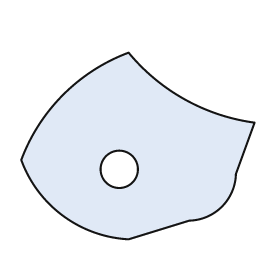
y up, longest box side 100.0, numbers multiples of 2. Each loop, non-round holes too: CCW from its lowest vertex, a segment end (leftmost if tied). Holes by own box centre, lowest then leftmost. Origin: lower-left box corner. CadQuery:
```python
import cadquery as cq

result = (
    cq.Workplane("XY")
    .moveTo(46.0, 0.0)
    .lineTo(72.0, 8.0)
    .threePointArc((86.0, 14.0), (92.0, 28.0))
    .lineTo(100.0, 50.0)
    .threePointArc((70.0, 60.0), (46.0, 80.0))
    .threePointArc((18.0, 62.0), (0.0, 34.0))
    .threePointArc((18.0, 10.0), (46.0, 0.0))
    .close()
    .moveTo(42.0, 30.0)
    .circle(8.0)
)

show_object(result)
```